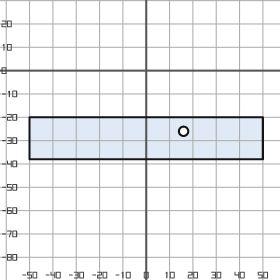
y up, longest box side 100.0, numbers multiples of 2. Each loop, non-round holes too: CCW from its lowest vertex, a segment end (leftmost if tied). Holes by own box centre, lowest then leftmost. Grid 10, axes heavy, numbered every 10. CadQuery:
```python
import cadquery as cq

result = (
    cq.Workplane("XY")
    .moveTo(-50.0, -38.0)
    .lineTo(50.0, -38.0)
    .lineTo(50.0, -20.0)
    .lineTo(-50.0, -20.0)
    .close()
    .moveTo(16.0, -26.0)
    .circle(2.0)
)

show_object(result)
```